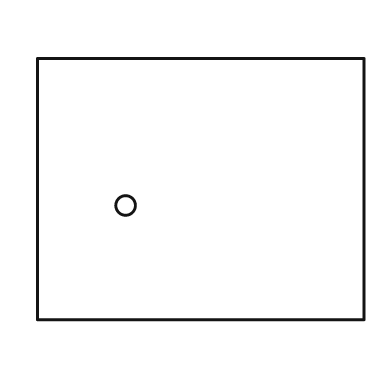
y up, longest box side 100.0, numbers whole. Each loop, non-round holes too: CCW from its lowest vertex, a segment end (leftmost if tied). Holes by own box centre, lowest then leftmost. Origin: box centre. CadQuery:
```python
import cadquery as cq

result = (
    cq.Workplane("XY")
    .moveTo(-50.0, -40.0)
    .lineTo(50.0, -40.0)
    .lineTo(50.0, 40.0)
    .lineTo(-50.0, 40.0)
    .close()
    .moveTo(-23.0, -5.0)
    .circle(3.0)
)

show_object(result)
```